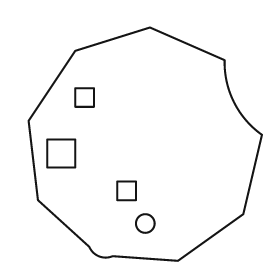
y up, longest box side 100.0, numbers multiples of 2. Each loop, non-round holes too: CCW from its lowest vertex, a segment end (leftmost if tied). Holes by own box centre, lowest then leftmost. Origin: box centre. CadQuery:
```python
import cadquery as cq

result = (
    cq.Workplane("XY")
    .moveTo(14.0, -50.0)
    .lineTo(42.0, -30.0)
    .lineTo(50.0, 4.0)
    .threePointArc((38.0, 18.0), (34.0, 36.0))
    .lineTo(2.0, 50.0)
    .lineTo(-30.0, 40.0)
    .lineTo(-50.0, 10.0)
    .lineTo(-46.0, -24.0)
    .lineTo(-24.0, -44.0)
    .threePointArc((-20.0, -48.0), (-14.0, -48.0))
    .close()
    .moveTo(0.0, -34.0)
    .circle(4.0)
    .moveTo(-12.0, -24.0)
    .lineTo(-4.0, -24.0)
    .lineTo(-4.0, -16.0)
    .lineTo(-12.0, -16.0)
    .close()
    .moveTo(-42.0, -10.0)
    .lineTo(-30.0, -10.0)
    .lineTo(-30.0, 2.0)
    .lineTo(-42.0, 2.0)
    .close()
    .moveTo(-30.0, 16.0)
    .lineTo(-22.0, 16.0)
    .lineTo(-22.0, 24.0)
    .lineTo(-30.0, 24.0)
    .close()
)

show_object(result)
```